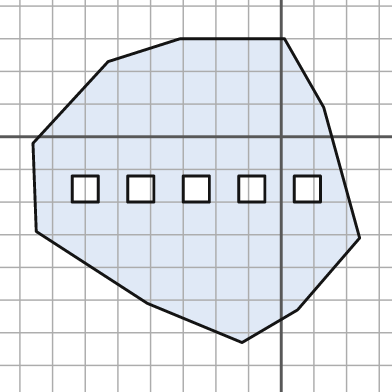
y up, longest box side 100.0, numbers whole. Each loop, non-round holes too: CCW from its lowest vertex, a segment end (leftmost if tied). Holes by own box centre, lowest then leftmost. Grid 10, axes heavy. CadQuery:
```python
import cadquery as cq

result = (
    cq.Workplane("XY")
    .moveTo(-12.0, -63.0)
    .lineTo(5.0, -53.0)
    .lineTo(24.0, -31.0)
    .lineTo(13.0, 9.0)
    .lineTo(1.0, 30.0)
    .lineTo(-31.0, 30.0)
    .lineTo(-53.0, 23.0)
    .lineTo(-76.0, -2.0)
    .lineTo(-75.0, -29.0)
    .lineTo(-41.0, -51.0)
    .close()
    .moveTo(-64.0, -20.0)
    .lineTo(-56.0, -20.0)
    .lineTo(-56.0, -12.0)
    .lineTo(-64.0, -12.0)
    .close()
    .moveTo(-47.0, -20.0)
    .lineTo(-39.0, -20.0)
    .lineTo(-39.0, -12.0)
    .lineTo(-47.0, -12.0)
    .close()
    .moveTo(-30.0, -20.0)
    .lineTo(-22.0, -20.0)
    .lineTo(-22.0, -12.0)
    .lineTo(-30.0, -12.0)
    .close()
    .moveTo(-13.0, -20.0)
    .lineTo(-5.0, -20.0)
    .lineTo(-5.0, -12.0)
    .lineTo(-13.0, -12.0)
    .close()
    .moveTo(4.0, -20.0)
    .lineTo(12.0, -20.0)
    .lineTo(12.0, -12.0)
    .lineTo(4.0, -12.0)
    .close()
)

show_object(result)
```